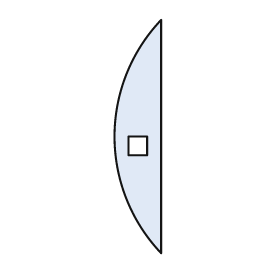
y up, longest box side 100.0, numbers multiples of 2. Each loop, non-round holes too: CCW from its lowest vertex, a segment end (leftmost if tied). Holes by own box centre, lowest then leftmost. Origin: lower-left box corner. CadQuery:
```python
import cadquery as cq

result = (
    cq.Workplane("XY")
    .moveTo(20.0, 0.0)
    .lineTo(20.0, 100.0)
    .threePointArc((0.0, 50.0), (20.0, 0.0))
    .close()
    .moveTo(6.0, 42.0)
    .lineTo(14.0, 42.0)
    .lineTo(14.0, 50.0)
    .lineTo(6.0, 50.0)
    .close()
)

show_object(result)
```